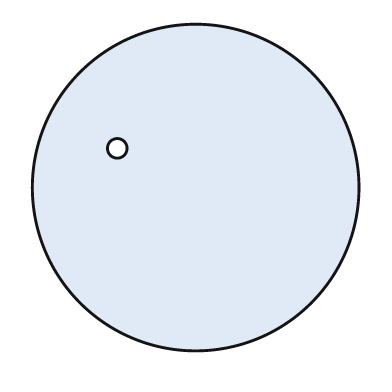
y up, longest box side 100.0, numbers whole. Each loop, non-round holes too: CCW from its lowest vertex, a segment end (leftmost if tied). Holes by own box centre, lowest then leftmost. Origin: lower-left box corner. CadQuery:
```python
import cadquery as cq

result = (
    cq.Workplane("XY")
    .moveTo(50.0, 50.0)
    .circle(50.0)
    .moveTo(26.0, 62.0)
    .circle(3.0)
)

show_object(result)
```